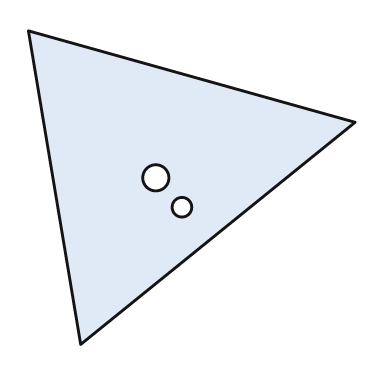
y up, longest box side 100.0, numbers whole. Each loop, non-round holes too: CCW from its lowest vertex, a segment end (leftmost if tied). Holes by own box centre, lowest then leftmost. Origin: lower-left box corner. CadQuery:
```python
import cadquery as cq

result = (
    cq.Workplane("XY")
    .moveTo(16.0, 0.0)
    .lineTo(100.0, 68.0)
    .lineTo(0.0, 96.0)
    .close()
    .moveTo(47.0, 42.0)
    .circle(3.0)
    .moveTo(39.0, 51.0)
    .circle(4.0)
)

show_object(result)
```